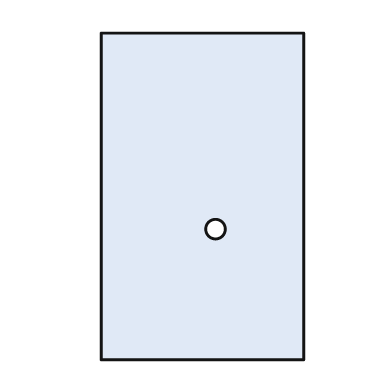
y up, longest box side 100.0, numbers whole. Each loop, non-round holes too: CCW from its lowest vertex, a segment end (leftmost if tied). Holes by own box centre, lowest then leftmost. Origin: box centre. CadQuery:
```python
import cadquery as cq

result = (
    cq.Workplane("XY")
    .moveTo(-31.0, -50.0)
    .lineTo(31.0, -50.0)
    .lineTo(31.0, 50.0)
    .lineTo(-31.0, 50.0)
    .close()
    .moveTo(4.0, -10.0)
    .circle(3.0)
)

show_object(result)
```